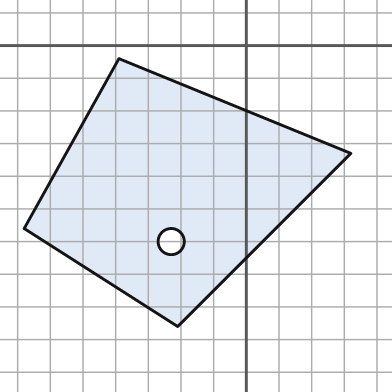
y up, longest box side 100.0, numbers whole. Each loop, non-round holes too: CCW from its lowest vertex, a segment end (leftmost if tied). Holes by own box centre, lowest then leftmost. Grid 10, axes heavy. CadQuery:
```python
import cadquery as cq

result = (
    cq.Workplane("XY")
    .moveTo(-21.0, -86.0)
    .lineTo(32.0, -33.0)
    .lineTo(-39.0, -4.0)
    .lineTo(-68.0, -56.0)
    .close()
    .moveTo(-23.0, -60.0)
    .circle(4.0)
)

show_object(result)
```